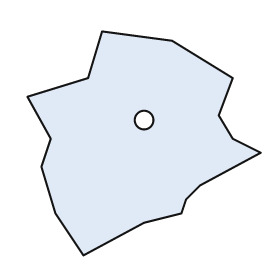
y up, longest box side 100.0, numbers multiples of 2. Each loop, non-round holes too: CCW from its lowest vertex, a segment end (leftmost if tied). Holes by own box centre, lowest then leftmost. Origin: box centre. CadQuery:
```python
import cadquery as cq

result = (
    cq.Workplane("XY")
    .moveTo(-26.0, -48.0)
    .lineTo(0.0, -34.0)
    .lineTo(16.0, -30.0)
    .lineTo(18.0, -24.0)
    .lineTo(24.0, -18.0)
    .lineTo(50.0, -4.0)
    .lineTo(38.0, 2.0)
    .lineTo(32.0, 12.0)
    .lineTo(38.0, 28.0)
    .lineTo(12.0, 44.0)
    .lineTo(-18.0, 48.0)
    .lineTo(-24.0, 28.0)
    .lineTo(-50.0, 20.0)
    .lineTo(-40.0, 2.0)
    .lineTo(-44.0, -10.0)
    .lineTo(-38.0, -30.0)
    .close()
    .moveTo(0.0, 10.0)
    .circle(4.0)
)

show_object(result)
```